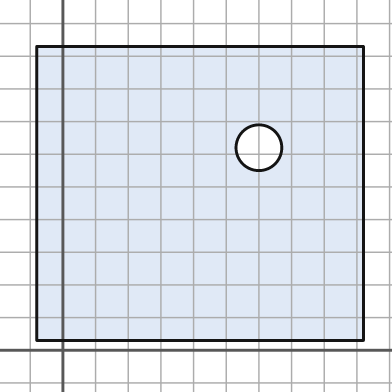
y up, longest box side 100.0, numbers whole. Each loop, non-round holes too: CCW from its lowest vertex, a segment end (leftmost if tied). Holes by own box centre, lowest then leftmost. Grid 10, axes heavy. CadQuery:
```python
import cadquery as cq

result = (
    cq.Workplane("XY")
    .moveTo(-8.0, 3.0)
    .lineTo(92.0, 3.0)
    .lineTo(92.0, 93.0)
    .lineTo(-8.0, 93.0)
    .close()
    .moveTo(60.0, 62.0)
    .circle(7.0)
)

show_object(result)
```